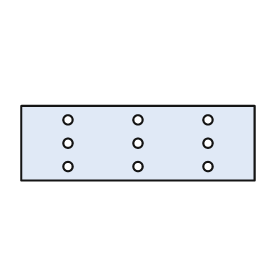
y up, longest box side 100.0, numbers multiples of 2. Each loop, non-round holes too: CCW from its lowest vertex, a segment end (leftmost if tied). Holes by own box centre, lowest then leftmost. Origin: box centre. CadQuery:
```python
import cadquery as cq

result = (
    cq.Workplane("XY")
    .moveTo(-50.0, -16.0)
    .lineTo(50.0, -16.0)
    .lineTo(50.0, 16.0)
    .lineTo(-50.0, 16.0)
    .close()
    .moveTo(-30.0, -10.0)
    .circle(2.0)
    .moveTo(0.0, -10.0)
    .circle(2.0)
    .moveTo(30.0, -10.0)
    .circle(2.0)
    .moveTo(-30.0, 0.0)
    .circle(2.0)
    .moveTo(0.0, 0.0)
    .circle(2.0)
    .moveTo(30.0, 0.0)
    .circle(2.0)
    .moveTo(-30.0, 10.0)
    .circle(2.0)
    .moveTo(0.0, 10.0)
    .circle(2.0)
    .moveTo(30.0, 10.0)
    .circle(2.0)
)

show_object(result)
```